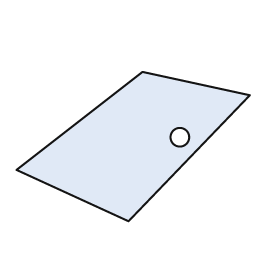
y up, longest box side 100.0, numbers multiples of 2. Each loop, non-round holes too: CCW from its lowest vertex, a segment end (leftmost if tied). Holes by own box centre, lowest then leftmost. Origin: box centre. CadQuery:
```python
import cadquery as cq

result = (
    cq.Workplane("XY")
    .moveTo(-2.0, -32.0)
    .lineTo(50.0, 22.0)
    .lineTo(4.0, 32.0)
    .lineTo(-50.0, -10.0)
    .close()
    .moveTo(20.0, 4.0)
    .circle(4.0)
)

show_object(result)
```